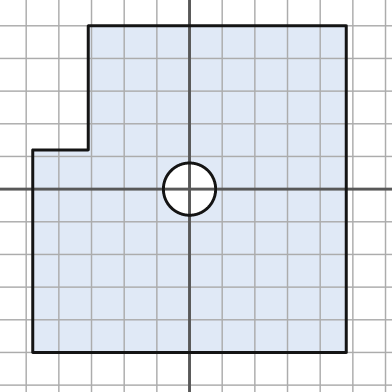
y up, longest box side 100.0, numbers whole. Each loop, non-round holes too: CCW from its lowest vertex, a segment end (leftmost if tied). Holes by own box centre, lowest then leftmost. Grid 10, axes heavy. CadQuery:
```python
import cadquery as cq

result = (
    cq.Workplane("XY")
    .moveTo(-48.0, -50.0)
    .lineTo(48.0, -50.0)
    .lineTo(48.0, 50.0)
    .lineTo(-31.0, 50.0)
    .lineTo(-31.0, 12.0)
    .lineTo(-48.0, 12.0)
    .close()
    .moveTo(0.0, 0.0)
    .circle(8.0)
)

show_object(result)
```